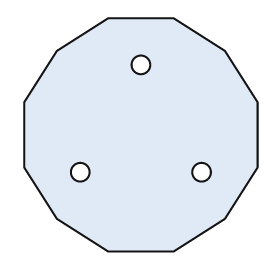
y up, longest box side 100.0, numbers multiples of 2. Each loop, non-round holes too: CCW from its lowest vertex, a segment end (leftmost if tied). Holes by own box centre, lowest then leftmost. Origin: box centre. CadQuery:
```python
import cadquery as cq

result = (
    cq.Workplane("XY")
    .moveTo(-14.0, -50.0)
    .lineTo(14.0, -50.0)
    .lineTo(36.0, -36.0)
    .lineTo(50.0, -14.0)
    .lineTo(50.0, 14.0)
    .lineTo(36.0, 36.0)
    .lineTo(14.0, 50.0)
    .lineTo(-14.0, 50.0)
    .lineTo(-36.0, 36.0)
    .lineTo(-50.0, 14.0)
    .lineTo(-50.0, -14.0)
    .lineTo(-36.0, -36.0)
    .close()
    .moveTo(-26.0, -16.0)
    .circle(4.0)
    .moveTo(26.0, -16.0)
    .circle(4.0)
    .moveTo(0.0, 30.0)
    .circle(4.0)
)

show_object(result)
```